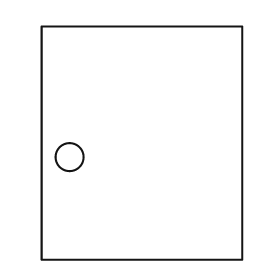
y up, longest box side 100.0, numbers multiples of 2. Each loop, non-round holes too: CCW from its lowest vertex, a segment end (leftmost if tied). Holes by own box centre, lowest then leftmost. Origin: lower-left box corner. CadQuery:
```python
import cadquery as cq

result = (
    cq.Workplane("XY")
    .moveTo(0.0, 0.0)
    .lineTo(86.0, 0.0)
    .lineTo(86.0, 100.0)
    .lineTo(0.0, 100.0)
    .close()
    .moveTo(12.0, 44.0)
    .circle(6.0)
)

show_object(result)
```